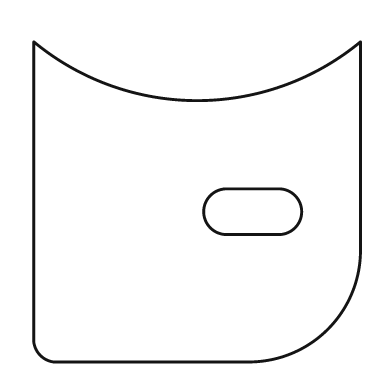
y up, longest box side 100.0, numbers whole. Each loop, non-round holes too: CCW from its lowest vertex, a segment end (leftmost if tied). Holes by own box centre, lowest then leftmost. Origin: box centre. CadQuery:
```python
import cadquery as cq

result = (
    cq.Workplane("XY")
    .moveTo(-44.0, -49.0)
    .lineTo(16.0, -49.0)
    .threePointArc((40.0, -39.0), (50.0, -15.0))
    .lineTo(50.0, 49.0)
    .threePointArc((0.0, 31.0), (-50.0, 49.0))
    .lineTo(-50.0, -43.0)
    .threePointArc((-48.0, -47.0), (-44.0, -49.0))
    .close()
    .moveTo(9.0, -10.0)
    .lineTo(25.0, -10.0)
    .threePointArc((32.0, -3.0), (25.0, 4.0))
    .lineTo(9.0, 4.0)
    .threePointArc((2.0, -3.0), (9.0, -10.0))
    .close()
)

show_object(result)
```